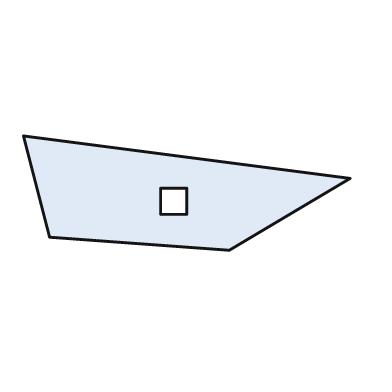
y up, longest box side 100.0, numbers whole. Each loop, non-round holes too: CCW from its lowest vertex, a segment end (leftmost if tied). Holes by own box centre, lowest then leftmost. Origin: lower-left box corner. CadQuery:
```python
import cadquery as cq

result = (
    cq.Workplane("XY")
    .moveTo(63.0, 0.0)
    .lineTo(100.0, 22.0)
    .lineTo(0.0, 35.0)
    .lineTo(8.0, 4.0)
    .close()
    .moveTo(42.0, 11.0)
    .lineTo(50.0, 11.0)
    .lineTo(50.0, 19.0)
    .lineTo(42.0, 19.0)
    .close()
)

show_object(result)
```